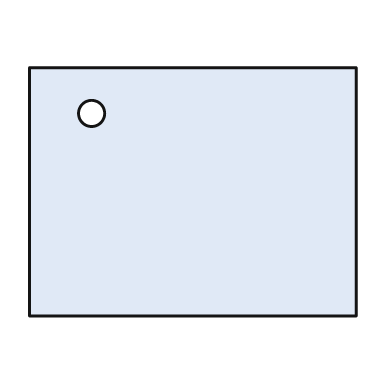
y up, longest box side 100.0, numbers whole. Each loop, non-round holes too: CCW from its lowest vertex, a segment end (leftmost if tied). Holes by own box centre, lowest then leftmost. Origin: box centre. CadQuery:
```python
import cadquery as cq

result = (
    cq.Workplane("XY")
    .moveTo(-50.0, -38.0)
    .lineTo(50.0, -38.0)
    .lineTo(50.0, 38.0)
    .lineTo(-50.0, 38.0)
    .close()
    .moveTo(-31.0, 24.0)
    .circle(4.0)
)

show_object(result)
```